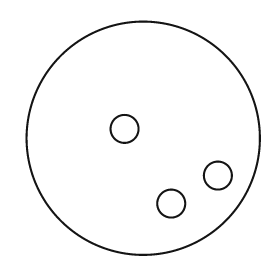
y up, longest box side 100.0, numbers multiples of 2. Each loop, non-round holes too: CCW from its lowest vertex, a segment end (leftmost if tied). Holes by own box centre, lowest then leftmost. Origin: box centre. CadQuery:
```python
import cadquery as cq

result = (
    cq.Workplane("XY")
    .moveTo(0.0, 0.0)
    .circle(50.0)
    .moveTo(12.0, -28.0)
    .circle(6.0)
    .moveTo(32.0, -16.0)
    .circle(6.0)
    .moveTo(-8.0, 4.0)
    .circle(6.0)
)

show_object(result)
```